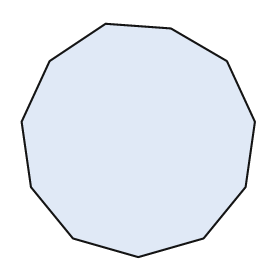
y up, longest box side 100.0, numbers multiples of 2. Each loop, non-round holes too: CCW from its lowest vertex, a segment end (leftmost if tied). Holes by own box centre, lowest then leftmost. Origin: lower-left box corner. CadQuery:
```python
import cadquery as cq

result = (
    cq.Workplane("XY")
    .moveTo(50.0, 0.0)
    .lineTo(78.0, 8.0)
    .lineTo(96.0, 30.0)
    .lineTo(100.0, 58.0)
    .lineTo(88.0, 84.0)
    .lineTo(64.0, 98.0)
    .lineTo(36.0, 100.0)
    .lineTo(12.0, 84.0)
    .lineTo(0.0, 58.0)
    .lineTo(4.0, 30.0)
    .lineTo(22.0, 8.0)
    .close()
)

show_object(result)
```